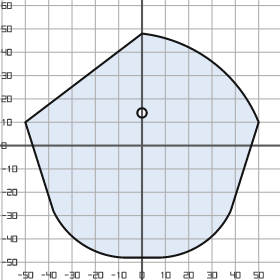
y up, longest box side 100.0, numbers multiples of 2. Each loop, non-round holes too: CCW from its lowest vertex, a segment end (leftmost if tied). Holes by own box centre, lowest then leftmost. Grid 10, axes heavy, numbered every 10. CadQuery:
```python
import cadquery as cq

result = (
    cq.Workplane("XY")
    .moveTo(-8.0, -48.0)
    .lineTo(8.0, -48.0)
    .threePointArc((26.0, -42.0), (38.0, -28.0))
    .lineTo(50.0, 10.0)
    .threePointArc((30.0, 36.0), (0.0, 48.0))
    .lineTo(-50.0, 10.0)
    .lineTo(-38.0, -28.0)
    .threePointArc((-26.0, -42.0), (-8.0, -48.0))
    .close()
    .moveTo(0.0, 14.0)
    .circle(2.0)
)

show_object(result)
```